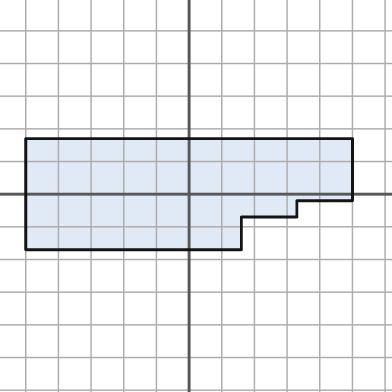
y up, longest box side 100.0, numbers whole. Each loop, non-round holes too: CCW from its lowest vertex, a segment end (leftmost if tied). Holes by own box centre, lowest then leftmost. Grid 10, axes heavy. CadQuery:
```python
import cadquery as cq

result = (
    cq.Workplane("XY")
    .moveTo(-50.0, -17.0)
    .lineTo(16.0, -17.0)
    .lineTo(16.0, -7.0)
    .lineTo(33.0, -7.0)
    .lineTo(33.0, -2.0)
    .lineTo(50.0, -2.0)
    .lineTo(50.0, 17.0)
    .lineTo(-50.0, 17.0)
    .close()
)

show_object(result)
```